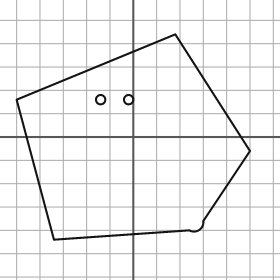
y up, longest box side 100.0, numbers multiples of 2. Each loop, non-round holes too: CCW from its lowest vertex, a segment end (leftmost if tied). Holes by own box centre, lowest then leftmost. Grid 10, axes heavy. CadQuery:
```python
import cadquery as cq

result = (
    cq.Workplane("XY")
    .moveTo(-34.0, -44.0)
    .lineTo(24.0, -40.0)
    .threePointArc((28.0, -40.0), (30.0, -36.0))
    .lineTo(50.0, -6.0)
    .lineTo(18.0, 44.0)
    .lineTo(-50.0, 16.0)
    .close()
    .moveTo(-14.0, 16.0)
    .circle(2.0)
    .moveTo(-2.0, 16.0)
    .circle(2.0)
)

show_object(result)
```